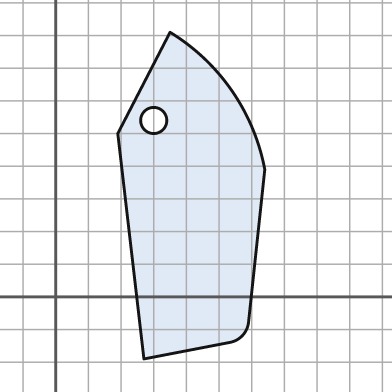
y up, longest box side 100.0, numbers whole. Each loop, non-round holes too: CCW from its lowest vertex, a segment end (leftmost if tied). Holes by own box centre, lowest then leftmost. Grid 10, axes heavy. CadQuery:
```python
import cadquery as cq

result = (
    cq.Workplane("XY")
    .moveTo(27.0, -19.0)
    .lineTo(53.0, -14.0)
    .threePointArc((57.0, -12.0), (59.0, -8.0))
    .lineTo(64.0, 39.0)
    .threePointArc((54.0, 63.0), (35.0, 81.0))
    .lineTo(19.0, 50.0)
    .close()
    .moveTo(30.0, 54.0)
    .circle(4.0)
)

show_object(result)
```